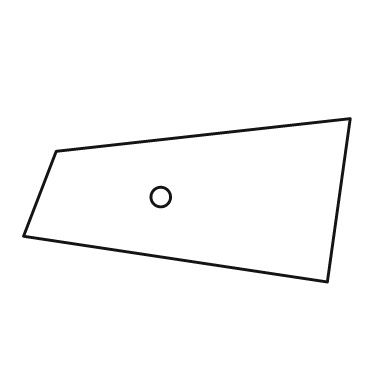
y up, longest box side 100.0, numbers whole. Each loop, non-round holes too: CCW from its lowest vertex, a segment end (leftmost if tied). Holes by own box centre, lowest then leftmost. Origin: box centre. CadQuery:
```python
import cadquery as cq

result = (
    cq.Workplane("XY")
    .moveTo(43.0, -25.0)
    .lineTo(50.0, 25.0)
    .lineTo(-40.0, 15.0)
    .lineTo(-50.0, -11.0)
    .close()
    .moveTo(-8.0, 1.0)
    .circle(3.0)
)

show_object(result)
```